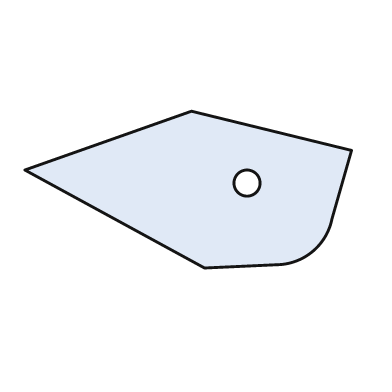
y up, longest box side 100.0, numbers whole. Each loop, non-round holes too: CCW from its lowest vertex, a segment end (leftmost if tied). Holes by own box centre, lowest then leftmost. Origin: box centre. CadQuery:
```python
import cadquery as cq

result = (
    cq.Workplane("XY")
    .moveTo(5.0, -24.0)
    .lineTo(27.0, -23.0)
    .threePointArc((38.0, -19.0), (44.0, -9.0))
    .lineTo(50.0, 12.0)
    .lineTo(1.0, 24.0)
    .lineTo(-50.0, 6.0)
    .close()
    .moveTo(18.0, 2.0)
    .circle(4.0)
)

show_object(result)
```